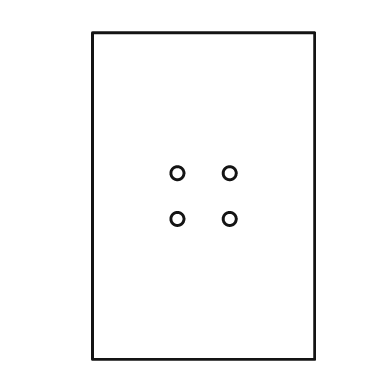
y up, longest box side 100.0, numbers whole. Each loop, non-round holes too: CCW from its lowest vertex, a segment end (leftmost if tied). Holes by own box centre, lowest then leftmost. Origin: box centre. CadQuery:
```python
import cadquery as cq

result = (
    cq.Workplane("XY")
    .moveTo(-34.0, -50.0)
    .lineTo(34.0, -50.0)
    .lineTo(34.0, 50.0)
    .lineTo(-34.0, 50.0)
    .close()
    .moveTo(-8.0, -7.0)
    .circle(2.0)
    .moveTo(8.0, -7.0)
    .circle(2.0)
    .moveTo(-8.0, 7.0)
    .circle(2.0)
    .moveTo(8.0, 7.0)
    .circle(2.0)
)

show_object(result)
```